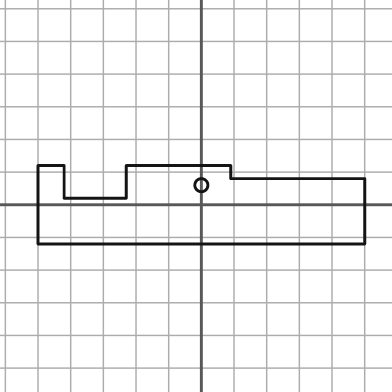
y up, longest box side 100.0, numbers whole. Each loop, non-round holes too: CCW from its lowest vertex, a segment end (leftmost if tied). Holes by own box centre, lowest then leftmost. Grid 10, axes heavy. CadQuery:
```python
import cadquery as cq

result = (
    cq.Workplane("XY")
    .moveTo(-50.0, -12.0)
    .lineTo(50.0, -12.0)
    .lineTo(50.0, 8.0)
    .lineTo(9.0, 8.0)
    .lineTo(9.0, 12.0)
    .lineTo(-23.0, 12.0)
    .lineTo(-23.0, 2.0)
    .lineTo(-42.0, 2.0)
    .lineTo(-42.0, 12.0)
    .lineTo(-50.0, 12.0)
    .close()
    .moveTo(0.0, 6.0)
    .circle(2.0)
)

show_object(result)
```